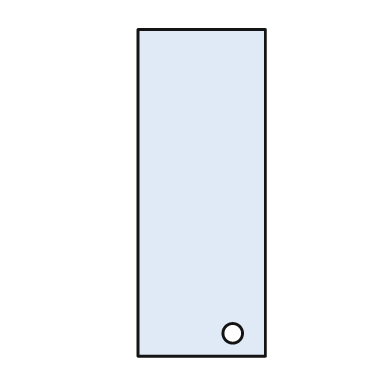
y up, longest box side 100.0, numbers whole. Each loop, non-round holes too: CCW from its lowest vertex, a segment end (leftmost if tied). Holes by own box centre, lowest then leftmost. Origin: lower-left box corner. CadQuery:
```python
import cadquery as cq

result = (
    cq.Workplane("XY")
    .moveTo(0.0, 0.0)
    .lineTo(39.0, 0.0)
    .lineTo(39.0, 100.0)
    .lineTo(0.0, 100.0)
    .close()
    .moveTo(29.0, 7.0)
    .circle(3.0)
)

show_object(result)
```